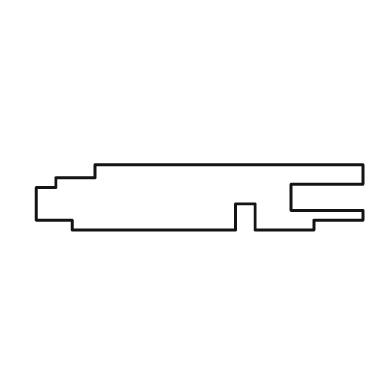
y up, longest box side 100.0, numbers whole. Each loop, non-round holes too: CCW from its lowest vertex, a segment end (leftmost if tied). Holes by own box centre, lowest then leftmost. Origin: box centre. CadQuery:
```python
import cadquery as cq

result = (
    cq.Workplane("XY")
    .moveTo(-39.0, -10.0)
    .lineTo(11.0, -10.0)
    .lineTo(11.0, -2.0)
    .lineTo(17.0, -2.0)
    .lineTo(17.0, -10.0)
    .lineTo(35.0, -10.0)
    .lineTo(35.0, -7.0)
    .lineTo(50.0, -7.0)
    .lineTo(50.0, -4.0)
    .lineTo(28.0, -4.0)
    .lineTo(28.0, 4.0)
    .lineTo(50.0, 4.0)
    .lineTo(50.0, 10.0)
    .lineTo(-32.0, 10.0)
    .lineTo(-32.0, 6.0)
    .lineTo(-44.0, 6.0)
    .lineTo(-44.0, 3.0)
    .lineTo(-50.0, 3.0)
    .lineTo(-50.0, -7.0)
    .lineTo(-39.0, -7.0)
    .close()
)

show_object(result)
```